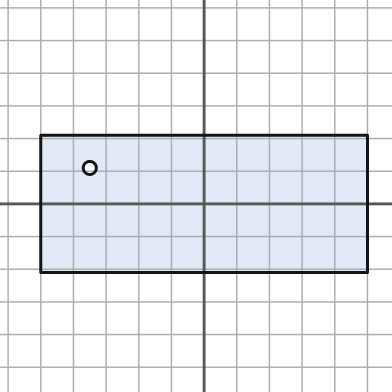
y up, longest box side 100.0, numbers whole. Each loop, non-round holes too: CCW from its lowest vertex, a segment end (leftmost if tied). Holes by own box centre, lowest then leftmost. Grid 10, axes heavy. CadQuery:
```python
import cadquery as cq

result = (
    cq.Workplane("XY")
    .moveTo(-50.0, -21.0)
    .lineTo(50.0, -21.0)
    .lineTo(50.0, 21.0)
    .lineTo(-50.0, 21.0)
    .close()
    .moveTo(-35.0, 11.0)
    .circle(2.0)
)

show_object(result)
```